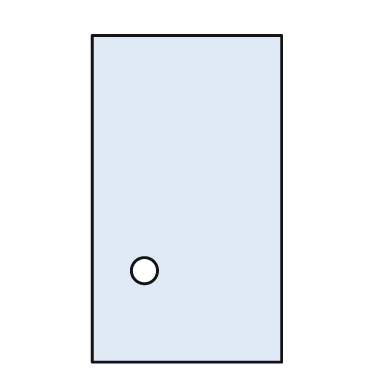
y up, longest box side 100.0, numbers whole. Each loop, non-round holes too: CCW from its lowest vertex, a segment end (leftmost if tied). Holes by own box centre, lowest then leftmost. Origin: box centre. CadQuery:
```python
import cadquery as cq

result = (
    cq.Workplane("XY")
    .moveTo(-29.0, -50.0)
    .lineTo(29.0, -50.0)
    .lineTo(29.0, 50.0)
    .lineTo(-29.0, 50.0)
    .close()
    .moveTo(-13.0, -22.0)
    .circle(4.0)
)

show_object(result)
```